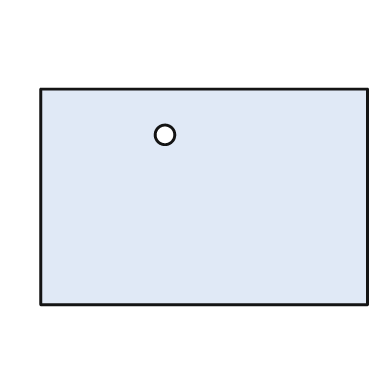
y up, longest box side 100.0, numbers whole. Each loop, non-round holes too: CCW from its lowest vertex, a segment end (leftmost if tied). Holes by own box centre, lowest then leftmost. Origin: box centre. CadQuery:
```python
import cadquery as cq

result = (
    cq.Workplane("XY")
    .moveTo(-50.0, -33.0)
    .lineTo(50.0, -33.0)
    .lineTo(50.0, 33.0)
    .lineTo(-50.0, 33.0)
    .close()
    .moveTo(-12.0, 19.0)
    .circle(3.0)
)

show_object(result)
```